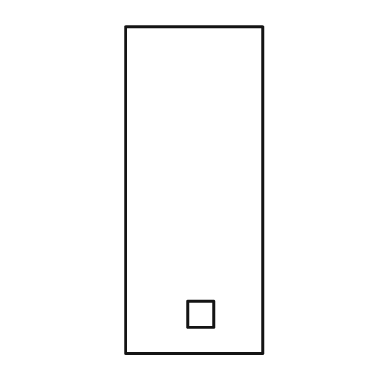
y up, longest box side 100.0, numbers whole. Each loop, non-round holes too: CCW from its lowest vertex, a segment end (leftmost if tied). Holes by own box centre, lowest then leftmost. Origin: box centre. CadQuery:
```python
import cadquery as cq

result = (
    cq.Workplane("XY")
    .moveTo(-21.0, -50.0)
    .lineTo(21.0, -50.0)
    .lineTo(21.0, 50.0)
    .lineTo(-21.0, 50.0)
    .close()
    .moveTo(-2.0, -42.0)
    .lineTo(6.0, -42.0)
    .lineTo(6.0, -34.0)
    .lineTo(-2.0, -34.0)
    .close()
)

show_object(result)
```